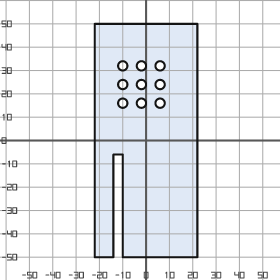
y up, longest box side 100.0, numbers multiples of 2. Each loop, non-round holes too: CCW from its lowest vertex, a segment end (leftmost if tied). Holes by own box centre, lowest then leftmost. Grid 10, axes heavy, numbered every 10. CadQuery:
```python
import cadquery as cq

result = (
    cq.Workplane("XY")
    .moveTo(-22.0, -50.0)
    .lineTo(-14.0, -50.0)
    .lineTo(-14.0, -6.0)
    .lineTo(-10.0, -6.0)
    .lineTo(-10.0, -50.0)
    .lineTo(22.0, -50.0)
    .lineTo(22.0, 50.0)
    .lineTo(-22.0, 50.0)
    .close()
    .moveTo(-10.0, 16.0)
    .circle(2.0)
    .moveTo(-2.0, 16.0)
    .circle(2.0)
    .moveTo(6.0, 16.0)
    .circle(2.0)
    .moveTo(-10.0, 24.0)
    .circle(2.0)
    .moveTo(-2.0, 24.0)
    .circle(2.0)
    .moveTo(6.0, 24.0)
    .circle(2.0)
    .moveTo(-10.0, 32.0)
    .circle(2.0)
    .moveTo(-2.0, 32.0)
    .circle(2.0)
    .moveTo(6.0, 32.0)
    .circle(2.0)
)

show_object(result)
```